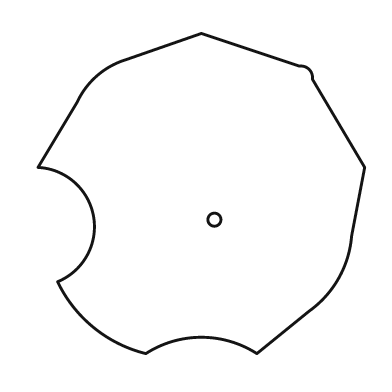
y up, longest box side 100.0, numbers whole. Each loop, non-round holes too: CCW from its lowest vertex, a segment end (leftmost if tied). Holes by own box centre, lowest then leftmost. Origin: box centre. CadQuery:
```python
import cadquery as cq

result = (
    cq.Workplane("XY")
    .moveTo(-17.0, -49.0)
    .threePointArc((0.0, -44.0), (17.0, -49.0))
    .lineTo(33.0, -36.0)
    .threePointArc((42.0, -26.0), (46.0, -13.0))
    .lineTo(50.0, 8.0)
    .lineTo(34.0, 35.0)
    .threePointArc((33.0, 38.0), (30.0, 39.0))
    .lineTo(0.0, 49.0)
    .lineTo(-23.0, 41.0)
    .threePointArc((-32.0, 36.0), (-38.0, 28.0))
    .lineTo(-50.0, 8.0)
    .threePointArc((-33.0, -7.0), (-44.0, -27.0))
    .threePointArc((-33.0, -41.0), (-17.0, -49.0))
    .close()
    .moveTo(4.0, -8.0)
    .circle(2.0)
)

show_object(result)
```